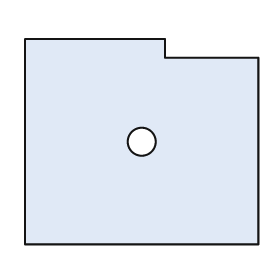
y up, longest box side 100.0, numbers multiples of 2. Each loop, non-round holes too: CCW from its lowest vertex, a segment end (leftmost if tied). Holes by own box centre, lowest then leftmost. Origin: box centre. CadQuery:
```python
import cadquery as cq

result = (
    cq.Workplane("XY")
    .moveTo(-50.0, -44.0)
    .lineTo(50.0, -44.0)
    .lineTo(50.0, 36.0)
    .lineTo(10.0, 36.0)
    .lineTo(10.0, 44.0)
    .lineTo(-50.0, 44.0)
    .close()
    .moveTo(0.0, 0.0)
    .circle(6.0)
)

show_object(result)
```